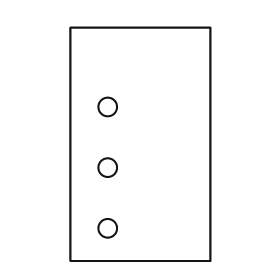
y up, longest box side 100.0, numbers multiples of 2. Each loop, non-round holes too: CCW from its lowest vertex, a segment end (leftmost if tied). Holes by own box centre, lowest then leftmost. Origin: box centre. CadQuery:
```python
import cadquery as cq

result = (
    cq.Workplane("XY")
    .moveTo(-30.0, -50.0)
    .lineTo(30.0, -50.0)
    .lineTo(30.0, 50.0)
    .lineTo(-30.0, 50.0)
    .close()
    .moveTo(-14.0, -36.0)
    .circle(4.0)
    .moveTo(-14.0, -10.0)
    .circle(4.0)
    .moveTo(-14.0, 16.0)
    .circle(4.0)
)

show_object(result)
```